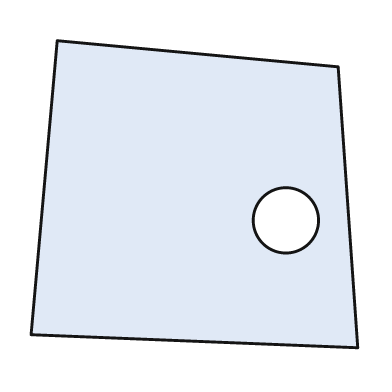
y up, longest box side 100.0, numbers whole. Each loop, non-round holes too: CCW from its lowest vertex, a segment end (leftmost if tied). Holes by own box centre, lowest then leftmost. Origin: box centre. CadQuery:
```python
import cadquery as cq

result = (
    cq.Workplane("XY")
    .moveTo(50.0, -47.0)
    .lineTo(44.0, 39.0)
    .lineTo(-42.0, 47.0)
    .lineTo(-50.0, -43.0)
    .close()
    .moveTo(28.0, -8.0)
    .circle(10.0)
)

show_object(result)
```